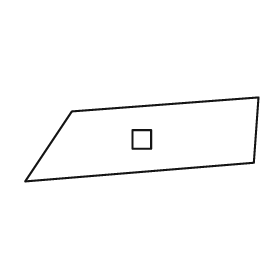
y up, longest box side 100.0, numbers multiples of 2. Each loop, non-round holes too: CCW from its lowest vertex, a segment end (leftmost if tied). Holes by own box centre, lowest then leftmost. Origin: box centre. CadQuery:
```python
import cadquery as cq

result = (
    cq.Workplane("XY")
    .moveTo(-50.0, -18.0)
    .lineTo(48.0, -10.0)
    .lineTo(50.0, 18.0)
    .lineTo(-30.0, 12.0)
    .close()
    .moveTo(-4.0, -4.0)
    .lineTo(4.0, -4.0)
    .lineTo(4.0, 4.0)
    .lineTo(-4.0, 4.0)
    .close()
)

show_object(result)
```